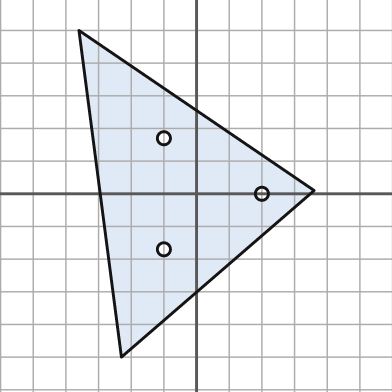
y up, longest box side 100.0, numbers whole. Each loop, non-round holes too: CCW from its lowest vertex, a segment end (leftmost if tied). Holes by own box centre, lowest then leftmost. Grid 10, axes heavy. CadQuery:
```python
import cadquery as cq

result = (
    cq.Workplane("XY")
    .moveTo(-23.0, -50.0)
    .lineTo(36.0, 1.0)
    .lineTo(-36.0, 50.0)
    .close()
    .moveTo(-10.0, -17.0)
    .circle(2.0)
    .moveTo(20.0, 0.0)
    .circle(2.0)
    .moveTo(-10.0, 17.0)
    .circle(2.0)
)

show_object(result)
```